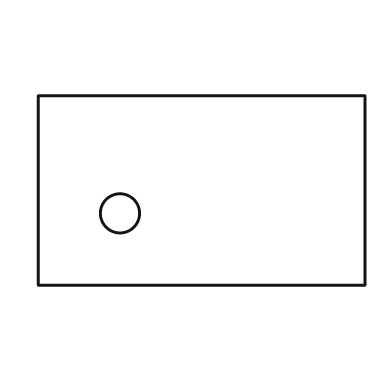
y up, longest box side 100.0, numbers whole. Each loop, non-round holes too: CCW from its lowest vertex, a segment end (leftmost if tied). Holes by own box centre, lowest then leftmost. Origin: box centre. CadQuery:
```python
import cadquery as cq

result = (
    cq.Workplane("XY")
    .moveTo(-50.0, -29.0)
    .lineTo(50.0, -29.0)
    .lineTo(50.0, 29.0)
    .lineTo(-50.0, 29.0)
    .close()
    .moveTo(-25.0, -7.0)
    .circle(6.0)
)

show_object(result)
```